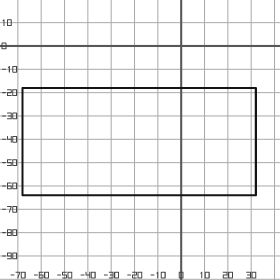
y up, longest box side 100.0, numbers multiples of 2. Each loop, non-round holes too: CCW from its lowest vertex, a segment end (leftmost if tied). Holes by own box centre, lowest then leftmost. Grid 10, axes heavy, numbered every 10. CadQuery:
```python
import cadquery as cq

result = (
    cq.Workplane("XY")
    .moveTo(-68.0, -64.0)
    .lineTo(32.0, -64.0)
    .lineTo(32.0, -18.0)
    .lineTo(-68.0, -18.0)
    .close()
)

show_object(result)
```